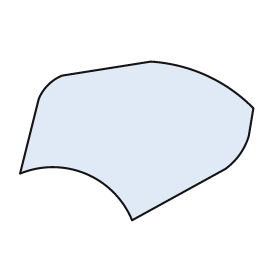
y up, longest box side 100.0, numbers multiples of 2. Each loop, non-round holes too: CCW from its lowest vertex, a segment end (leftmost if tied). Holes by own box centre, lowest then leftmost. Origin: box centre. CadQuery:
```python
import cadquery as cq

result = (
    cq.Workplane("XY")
    .moveTo(-2.0, -34.0)
    .lineTo(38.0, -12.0)
    .threePointArc((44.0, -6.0), (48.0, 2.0))
    .lineTo(50.0, 14.0)
    .threePointArc((30.0, 28.0), (6.0, 34.0))
    .lineTo(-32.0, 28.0)
    .threePointArc((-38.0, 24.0), (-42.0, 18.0))
    .lineTo(-50.0, -14.0)
    .threePointArc((-22.0, -14.0), (-2.0, -34.0))
    .close()
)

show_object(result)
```